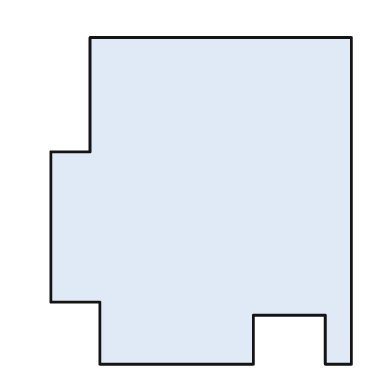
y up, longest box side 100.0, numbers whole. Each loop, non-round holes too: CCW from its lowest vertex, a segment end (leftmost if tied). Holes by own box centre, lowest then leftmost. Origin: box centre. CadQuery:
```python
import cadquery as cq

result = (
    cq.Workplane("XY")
    .moveTo(-31.0, -50.0)
    .lineTo(16.0, -50.0)
    .lineTo(16.0, -35.0)
    .lineTo(38.0, -35.0)
    .lineTo(38.0, -50.0)
    .lineTo(46.0, -50.0)
    .lineTo(46.0, 50.0)
    .lineTo(-34.0, 50.0)
    .lineTo(-34.0, 15.0)
    .lineTo(-46.0, 15.0)
    .lineTo(-46.0, -31.0)
    .lineTo(-31.0, -31.0)
    .close()
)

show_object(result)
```